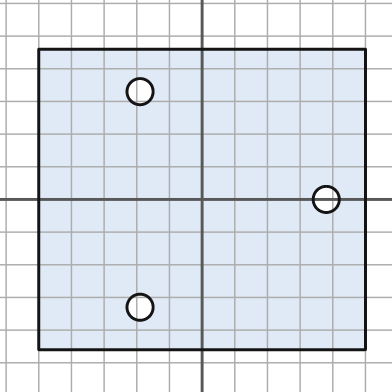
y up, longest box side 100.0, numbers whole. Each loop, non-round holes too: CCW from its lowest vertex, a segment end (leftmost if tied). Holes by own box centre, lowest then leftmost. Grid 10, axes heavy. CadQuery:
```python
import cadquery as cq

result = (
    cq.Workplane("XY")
    .moveTo(-50.0, -46.0)
    .lineTo(50.0, -46.0)
    .lineTo(50.0, 46.0)
    .lineTo(-50.0, 46.0)
    .close()
    .moveTo(-19.0, -33.0)
    .circle(4.0)
    .moveTo(38.0, 0.0)
    .circle(4.0)
    .moveTo(-19.0, 33.0)
    .circle(4.0)
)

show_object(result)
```